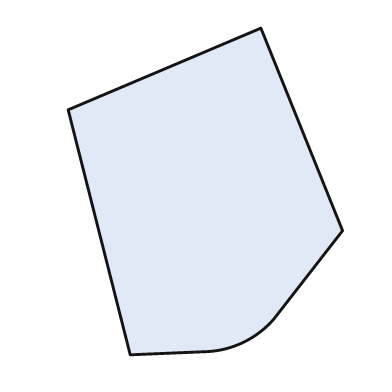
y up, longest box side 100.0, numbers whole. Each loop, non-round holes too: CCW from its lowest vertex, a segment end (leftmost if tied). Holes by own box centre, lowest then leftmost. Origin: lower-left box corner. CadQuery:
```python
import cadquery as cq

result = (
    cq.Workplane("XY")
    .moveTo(19.0, 0.0)
    .lineTo(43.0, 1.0)
    .threePointArc((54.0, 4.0), (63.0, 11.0))
    .lineTo(84.0, 38.0)
    .lineTo(59.0, 100.0)
    .lineTo(0.0, 75.0)
    .close()
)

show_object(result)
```